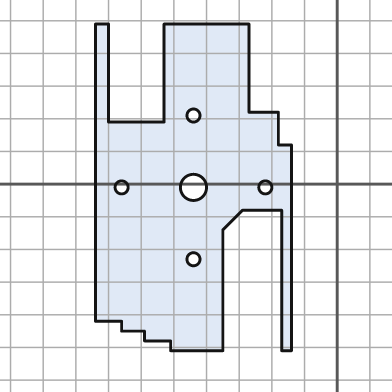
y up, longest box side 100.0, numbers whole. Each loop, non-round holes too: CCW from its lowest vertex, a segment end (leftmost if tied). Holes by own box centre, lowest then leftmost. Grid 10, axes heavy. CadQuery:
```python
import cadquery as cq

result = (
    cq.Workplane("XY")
    .moveTo(-51.0, -51.0)
    .lineTo(-35.0, -51.0)
    .lineTo(-35.0, -14.0)
    .lineTo(-29.0, -8.0)
    .lineTo(-17.0, -8.0)
    .lineTo(-17.0, -51.0)
    .lineTo(-14.0, -51.0)
    .lineTo(-14.0, 12.0)
    .lineTo(-18.0, 12.0)
    .lineTo(-18.0, 22.0)
    .lineTo(-27.0, 22.0)
    .lineTo(-27.0, 49.0)
    .lineTo(-53.0, 49.0)
    .lineTo(-53.0, 19.0)
    .lineTo(-70.0, 19.0)
    .lineTo(-70.0, 49.0)
    .lineTo(-74.0, 49.0)
    .lineTo(-74.0, -42.0)
    .lineTo(-66.0, -42.0)
    .lineTo(-66.0, -45.0)
    .lineTo(-59.0, -45.0)
    .lineTo(-59.0, -48.0)
    .lineTo(-51.0, -48.0)
    .close()
    .moveTo(-44.0, -23.0)
    .circle(2.0)
    .moveTo(-66.0, -1.0)
    .circle(2.0)
    .moveTo(-44.0, -1.0)
    .circle(4.0)
    .moveTo(-22.0, -1.0)
    .circle(2.0)
    .moveTo(-44.0, 21.0)
    .circle(2.0)
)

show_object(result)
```